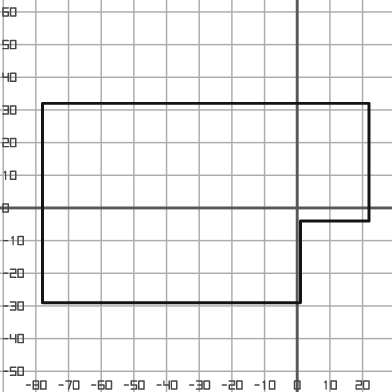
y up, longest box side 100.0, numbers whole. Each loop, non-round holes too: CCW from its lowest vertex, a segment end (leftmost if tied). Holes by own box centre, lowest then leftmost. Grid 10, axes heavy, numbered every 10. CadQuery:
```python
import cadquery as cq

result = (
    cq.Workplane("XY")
    .moveTo(-78.0, -29.0)
    .lineTo(1.0, -29.0)
    .lineTo(1.0, -4.0)
    .lineTo(22.0, -4.0)
    .lineTo(22.0, 32.0)
    .lineTo(-78.0, 32.0)
    .close()
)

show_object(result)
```